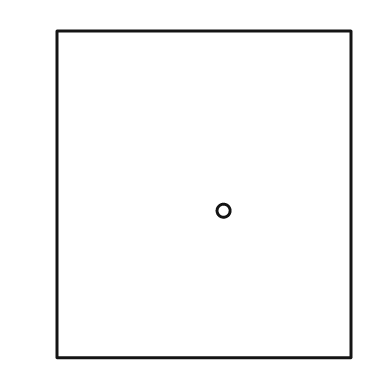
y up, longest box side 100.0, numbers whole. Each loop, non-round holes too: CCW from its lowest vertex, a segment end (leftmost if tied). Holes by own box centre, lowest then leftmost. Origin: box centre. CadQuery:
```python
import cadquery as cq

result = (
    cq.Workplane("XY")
    .moveTo(-45.0, -50.0)
    .lineTo(45.0, -50.0)
    .lineTo(45.0, 50.0)
    .lineTo(-45.0, 50.0)
    .close()
    .moveTo(6.0, -5.0)
    .circle(2.0)
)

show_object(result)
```